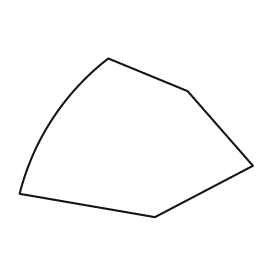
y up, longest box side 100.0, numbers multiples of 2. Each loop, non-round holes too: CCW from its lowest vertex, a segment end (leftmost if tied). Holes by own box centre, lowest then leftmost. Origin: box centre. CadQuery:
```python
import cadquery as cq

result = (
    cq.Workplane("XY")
    .moveTo(8.0, -34.0)
    .lineTo(50.0, -12.0)
    .lineTo(22.0, 20.0)
    .lineTo(-12.0, 34.0)
    .threePointArc((-36.0, 8.0), (-50.0, -24.0))
    .close()
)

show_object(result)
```